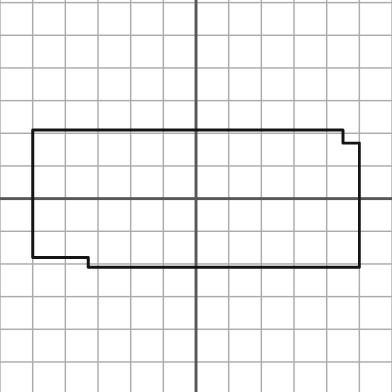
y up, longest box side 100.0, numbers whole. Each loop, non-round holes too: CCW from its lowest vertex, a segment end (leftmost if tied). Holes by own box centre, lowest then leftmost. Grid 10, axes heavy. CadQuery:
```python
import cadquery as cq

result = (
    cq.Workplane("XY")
    .moveTo(-33.0, -21.0)
    .lineTo(50.0, -21.0)
    .lineTo(50.0, 17.0)
    .lineTo(45.0, 17.0)
    .lineTo(45.0, 21.0)
    .lineTo(-50.0, 21.0)
    .lineTo(-50.0, -18.0)
    .lineTo(-33.0, -18.0)
    .close()
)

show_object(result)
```